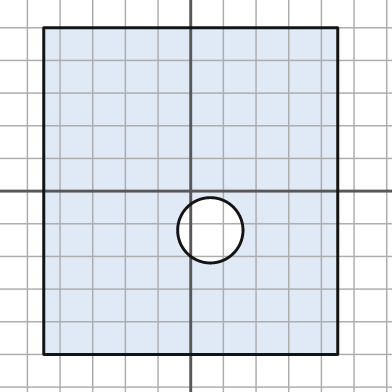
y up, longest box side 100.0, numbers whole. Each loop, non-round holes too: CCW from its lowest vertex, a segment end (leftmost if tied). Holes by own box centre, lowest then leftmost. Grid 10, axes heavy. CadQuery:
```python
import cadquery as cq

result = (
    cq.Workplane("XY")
    .moveTo(-45.0, -50.0)
    .lineTo(45.0, -50.0)
    .lineTo(45.0, 50.0)
    .lineTo(-45.0, 50.0)
    .close()
    .moveTo(6.0, -12.0)
    .circle(10.0)
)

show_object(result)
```